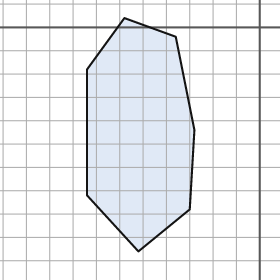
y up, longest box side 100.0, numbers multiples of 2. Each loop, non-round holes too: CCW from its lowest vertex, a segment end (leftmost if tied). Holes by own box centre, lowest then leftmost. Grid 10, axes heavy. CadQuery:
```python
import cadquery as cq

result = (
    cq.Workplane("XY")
    .moveTo(-52.0, -96.0)
    .lineTo(-30.0, -78.0)
    .lineTo(-28.0, -44.0)
    .lineTo(-36.0, -4.0)
    .lineTo(-58.0, 4.0)
    .lineTo(-74.0, -18.0)
    .lineTo(-74.0, -72.0)
    .close()
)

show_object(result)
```